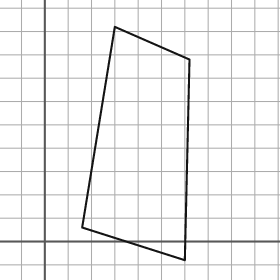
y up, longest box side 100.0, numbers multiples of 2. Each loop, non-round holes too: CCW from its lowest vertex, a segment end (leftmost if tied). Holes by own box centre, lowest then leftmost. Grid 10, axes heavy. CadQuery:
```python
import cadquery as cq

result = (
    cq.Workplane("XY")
    .moveTo(60.0, -8.0)
    .lineTo(62.0, 78.0)
    .lineTo(30.0, 92.0)
    .lineTo(16.0, 6.0)
    .close()
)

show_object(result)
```